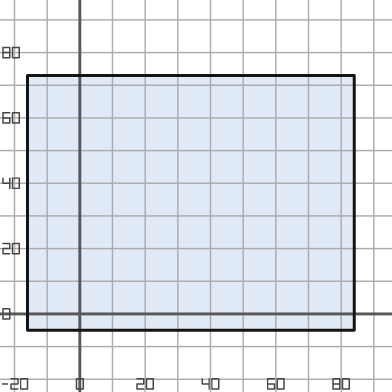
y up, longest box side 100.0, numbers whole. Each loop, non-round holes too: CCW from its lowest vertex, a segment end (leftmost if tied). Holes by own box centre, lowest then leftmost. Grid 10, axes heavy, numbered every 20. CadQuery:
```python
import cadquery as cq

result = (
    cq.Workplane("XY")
    .moveTo(-16.0, -5.0)
    .lineTo(84.0, -5.0)
    .lineTo(84.0, 73.0)
    .lineTo(-16.0, 73.0)
    .close()
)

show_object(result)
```